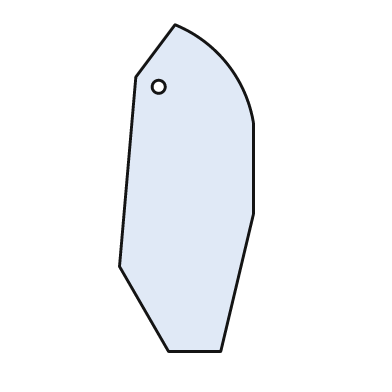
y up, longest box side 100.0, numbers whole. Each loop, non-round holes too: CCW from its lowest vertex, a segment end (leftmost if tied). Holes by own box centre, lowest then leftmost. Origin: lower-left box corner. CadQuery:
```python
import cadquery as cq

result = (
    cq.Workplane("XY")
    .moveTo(15.0, 0.0)
    .lineTo(31.0, 0.0)
    .lineTo(41.0, 42.0)
    .lineTo(41.0, 70.0)
    .threePointArc((33.0, 88.0), (17.0, 100.0))
    .lineTo(5.0, 84.0)
    .lineTo(0.0, 26.0)
    .close()
    .moveTo(12.0, 81.0)
    .circle(2.0)
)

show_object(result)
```